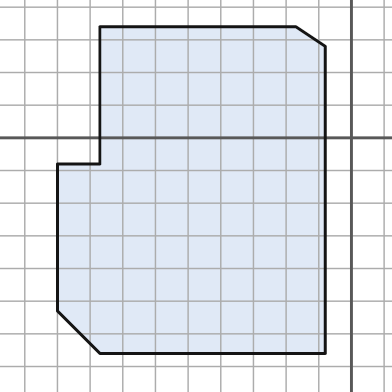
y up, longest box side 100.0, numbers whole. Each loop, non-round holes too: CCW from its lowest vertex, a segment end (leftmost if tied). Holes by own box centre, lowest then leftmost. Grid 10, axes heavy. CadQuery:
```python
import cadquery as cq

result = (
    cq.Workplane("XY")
    .moveTo(-77.0, -66.0)
    .lineTo(-8.0, -66.0)
    .lineTo(-8.0, 28.0)
    .lineTo(-17.0, 34.0)
    .lineTo(-77.0, 34.0)
    .lineTo(-77.0, -8.0)
    .lineTo(-90.0, -8.0)
    .lineTo(-90.0, -53.0)
    .close()
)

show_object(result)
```